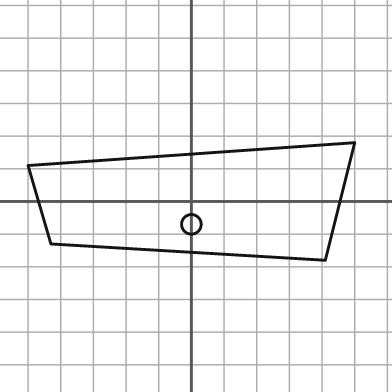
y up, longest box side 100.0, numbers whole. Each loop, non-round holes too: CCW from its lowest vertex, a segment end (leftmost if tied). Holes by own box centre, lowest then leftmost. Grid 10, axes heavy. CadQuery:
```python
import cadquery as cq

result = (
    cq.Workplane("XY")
    .moveTo(41.0, -18.0)
    .lineTo(50.0, 18.0)
    .lineTo(-50.0, 11.0)
    .lineTo(-43.0, -13.0)
    .close()
    .moveTo(0.0, -7.0)
    .circle(3.0)
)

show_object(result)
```